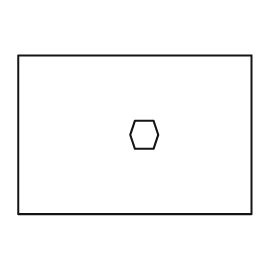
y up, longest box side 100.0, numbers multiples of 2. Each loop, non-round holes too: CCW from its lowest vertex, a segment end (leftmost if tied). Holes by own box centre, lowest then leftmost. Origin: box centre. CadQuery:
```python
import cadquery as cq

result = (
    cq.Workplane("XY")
    .moveTo(-50.0, -34.0)
    .lineTo(50.0, -34.0)
    .lineTo(50.0, 34.0)
    .lineTo(-50.0, 34.0)
    .close()
    .moveTo(0.0, -6.0)
    .lineTo(8.0, -6.0)
    .lineTo(10.0, 0.0)
    .lineTo(8.0, 6.0)
    .lineTo(0.0, 6.0)
    .lineTo(-2.0, 0.0)
    .close()
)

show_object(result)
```